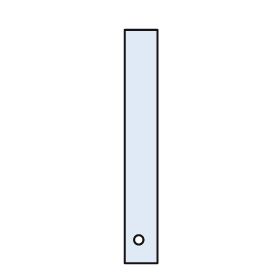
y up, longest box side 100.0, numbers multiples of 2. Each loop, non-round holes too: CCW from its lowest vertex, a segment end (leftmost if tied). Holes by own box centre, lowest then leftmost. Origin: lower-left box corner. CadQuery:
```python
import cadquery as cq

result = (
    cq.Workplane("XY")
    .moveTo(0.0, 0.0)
    .lineTo(14.0, 0.0)
    .lineTo(14.0, 100.0)
    .lineTo(0.0, 100.0)
    .close()
    .moveTo(6.0, 10.0)
    .circle(2.0)
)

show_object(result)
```